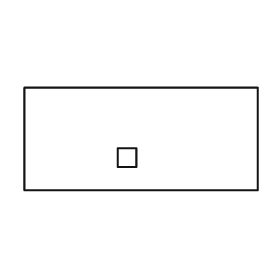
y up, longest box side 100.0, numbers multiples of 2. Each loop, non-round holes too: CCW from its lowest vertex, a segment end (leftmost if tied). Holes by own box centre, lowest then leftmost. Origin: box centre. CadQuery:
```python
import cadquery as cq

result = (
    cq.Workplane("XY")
    .moveTo(-50.0, -22.0)
    .lineTo(50.0, -22.0)
    .lineTo(50.0, 22.0)
    .lineTo(-50.0, 22.0)
    .close()
    .moveTo(-10.0, -12.0)
    .lineTo(-2.0, -12.0)
    .lineTo(-2.0, -4.0)
    .lineTo(-10.0, -4.0)
    .close()
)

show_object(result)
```